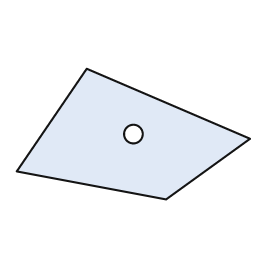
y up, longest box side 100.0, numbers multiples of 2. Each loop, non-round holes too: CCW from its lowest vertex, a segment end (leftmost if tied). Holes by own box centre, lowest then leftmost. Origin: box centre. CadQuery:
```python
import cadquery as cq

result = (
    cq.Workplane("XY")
    .moveTo(14.0, -28.0)
    .lineTo(50.0, -2.0)
    .lineTo(-20.0, 28.0)
    .lineTo(-50.0, -16.0)
    .close()
    .moveTo(0.0, 0.0)
    .circle(4.0)
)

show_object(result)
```